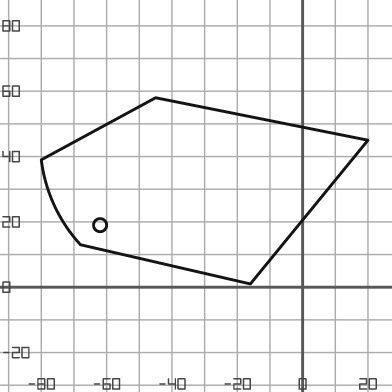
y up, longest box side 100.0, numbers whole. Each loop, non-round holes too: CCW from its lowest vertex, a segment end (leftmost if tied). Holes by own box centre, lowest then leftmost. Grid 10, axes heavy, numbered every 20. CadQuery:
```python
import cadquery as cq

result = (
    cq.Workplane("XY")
    .moveTo(-16.0, 1.0)
    .lineTo(20.0, 45.0)
    .lineTo(-45.0, 58.0)
    .lineTo(-80.0, 39.0)
    .threePointArc((-76.0, 25.0), (-68.0, 13.0))
    .close()
    .moveTo(-62.0, 19.0)
    .circle(2.0)
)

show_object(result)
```